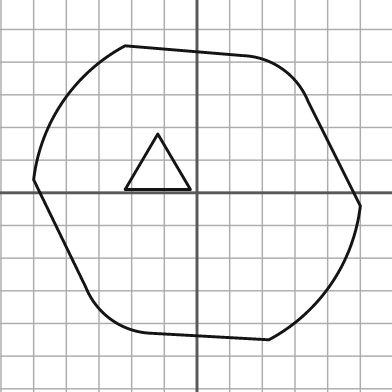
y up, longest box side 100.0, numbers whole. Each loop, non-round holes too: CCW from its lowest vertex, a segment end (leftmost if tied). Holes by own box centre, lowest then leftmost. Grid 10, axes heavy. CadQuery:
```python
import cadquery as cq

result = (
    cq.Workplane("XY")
    .moveTo(22.0, -45.0)
    .threePointArc((41.0, -28.0), (50.0, -4.0))
    .lineTo(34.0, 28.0)
    .threePointArc((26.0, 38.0), (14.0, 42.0))
    .lineTo(-22.0, 45.0)
    .threePointArc((-41.0, 28.0), (-50.0, 4.0))
    .lineTo(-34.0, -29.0)
    .threePointArc((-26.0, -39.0), (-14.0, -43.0))
    .close()
    .moveTo(-22.0, 1.0)
    .lineTo(-2.0, 1.0)
    .lineTo(-12.0, 18.0)
    .close()
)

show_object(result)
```